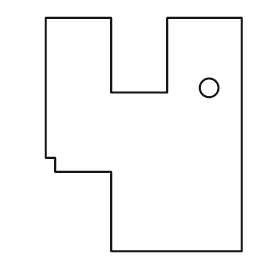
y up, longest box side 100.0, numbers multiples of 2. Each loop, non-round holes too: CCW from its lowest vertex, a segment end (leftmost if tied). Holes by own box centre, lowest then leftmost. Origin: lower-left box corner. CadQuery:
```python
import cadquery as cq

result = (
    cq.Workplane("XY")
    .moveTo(28.0, 0.0)
    .lineTo(84.0, 0.0)
    .lineTo(84.0, 100.0)
    .lineTo(52.0, 100.0)
    .lineTo(52.0, 68.0)
    .lineTo(28.0, 68.0)
    .lineTo(28.0, 100.0)
    .lineTo(0.0, 100.0)
    .lineTo(0.0, 40.0)
    .lineTo(4.0, 40.0)
    .lineTo(4.0, 34.0)
    .lineTo(28.0, 34.0)
    .close()
    .moveTo(70.0, 70.0)
    .circle(4.0)
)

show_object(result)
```